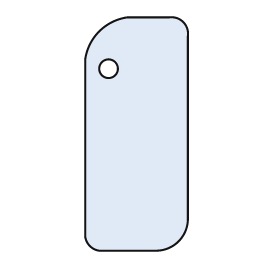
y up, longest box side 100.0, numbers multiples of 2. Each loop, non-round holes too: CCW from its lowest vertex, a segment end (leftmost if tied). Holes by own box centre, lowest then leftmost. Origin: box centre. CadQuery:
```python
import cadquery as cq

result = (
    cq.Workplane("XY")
    .moveTo(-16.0, -50.0)
    .lineTo(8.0, -50.0)
    .threePointArc((18.0, -46.0), (22.0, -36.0))
    .lineTo(22.0, 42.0)
    .threePointArc((20.0, 48.0), (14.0, 50.0))
    .lineTo(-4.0, 50.0)
    .threePointArc((-16.0, 44.0), (-22.0, 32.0))
    .lineTo(-22.0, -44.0)
    .threePointArc((-20.0, -48.0), (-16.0, -50.0))
    .close()
    .moveTo(-12.0, 28.0)
    .circle(4.0)
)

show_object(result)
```